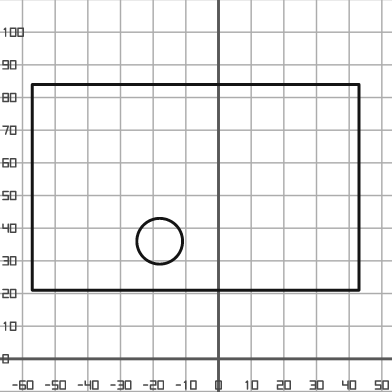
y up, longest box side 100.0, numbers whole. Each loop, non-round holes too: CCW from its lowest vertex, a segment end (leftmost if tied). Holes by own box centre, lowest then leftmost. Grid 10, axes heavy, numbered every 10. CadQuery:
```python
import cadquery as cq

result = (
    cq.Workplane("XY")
    .moveTo(-57.0, 21.0)
    .lineTo(43.0, 21.0)
    .lineTo(43.0, 84.0)
    .lineTo(-57.0, 84.0)
    .close()
    .moveTo(-18.0, 36.0)
    .circle(7.0)
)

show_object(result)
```